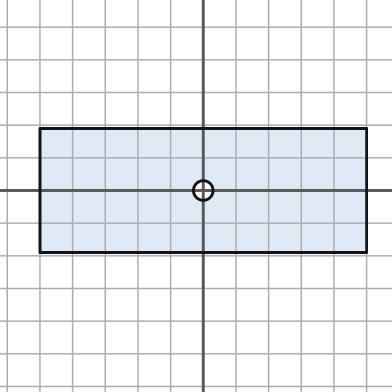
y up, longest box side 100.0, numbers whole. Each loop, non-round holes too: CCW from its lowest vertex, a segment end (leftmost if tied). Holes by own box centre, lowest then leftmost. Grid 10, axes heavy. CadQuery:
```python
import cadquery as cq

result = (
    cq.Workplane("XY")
    .moveTo(-50.0, -19.0)
    .lineTo(50.0, -19.0)
    .lineTo(50.0, 19.0)
    .lineTo(-50.0, 19.0)
    .close()
    .moveTo(0.0, 0.0)
    .circle(3.0)
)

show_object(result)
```